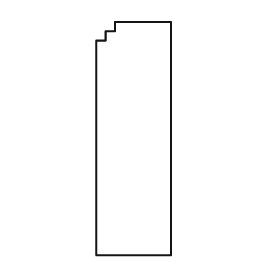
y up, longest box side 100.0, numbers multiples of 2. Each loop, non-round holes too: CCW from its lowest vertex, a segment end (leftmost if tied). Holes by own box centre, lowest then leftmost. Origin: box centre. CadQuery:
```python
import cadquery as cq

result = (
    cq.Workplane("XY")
    .moveTo(-16.0, -50.0)
    .lineTo(16.0, -50.0)
    .lineTo(16.0, 50.0)
    .lineTo(-8.0, 50.0)
    .lineTo(-8.0, 46.0)
    .lineTo(-12.0, 46.0)
    .lineTo(-12.0, 42.0)
    .lineTo(-16.0, 42.0)
    .close()
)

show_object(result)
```